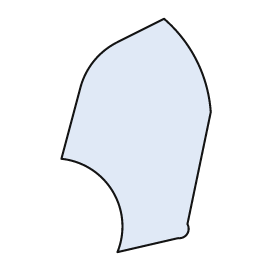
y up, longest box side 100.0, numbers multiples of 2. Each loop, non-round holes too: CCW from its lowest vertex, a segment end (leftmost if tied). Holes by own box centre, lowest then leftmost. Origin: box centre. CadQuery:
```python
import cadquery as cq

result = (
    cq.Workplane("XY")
    .moveTo(-8.0, -50.0)
    .lineTo(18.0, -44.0)
    .threePointArc((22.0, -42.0), (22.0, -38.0))
    .lineTo(32.0, 10.0)
    .threePointArc((26.0, 32.0), (12.0, 50.0))
    .lineTo(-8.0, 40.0)
    .threePointArc((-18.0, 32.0), (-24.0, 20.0))
    .lineTo(-32.0, -10.0)
    .threePointArc((-10.0, -24.0), (-8.0, -50.0))
    .close()
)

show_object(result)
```